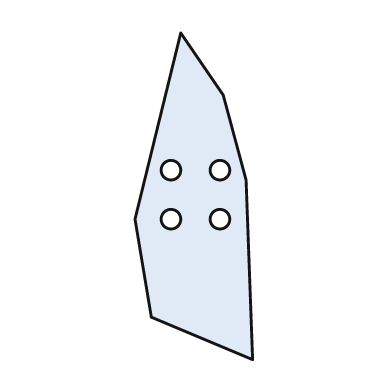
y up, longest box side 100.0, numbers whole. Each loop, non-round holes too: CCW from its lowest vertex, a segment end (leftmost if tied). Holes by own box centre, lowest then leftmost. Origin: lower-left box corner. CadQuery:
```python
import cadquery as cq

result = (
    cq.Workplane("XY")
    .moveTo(36.0, 0.0)
    .lineTo(34.0, 55.0)
    .lineTo(27.0, 81.0)
    .lineTo(14.0, 100.0)
    .lineTo(0.0, 43.0)
    .lineTo(5.0, 13.0)
    .close()
    .moveTo(11.0, 43.0)
    .circle(3.0)
    .moveTo(26.0, 43.0)
    .circle(3.0)
    .moveTo(11.0, 58.0)
    .circle(3.0)
    .moveTo(26.0, 58.0)
    .circle(3.0)
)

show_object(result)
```